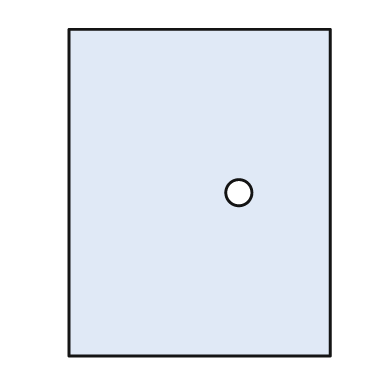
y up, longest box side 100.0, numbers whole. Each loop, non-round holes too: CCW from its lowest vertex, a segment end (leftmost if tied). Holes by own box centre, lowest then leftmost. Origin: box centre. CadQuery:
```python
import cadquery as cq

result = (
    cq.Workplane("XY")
    .moveTo(-40.0, -50.0)
    .lineTo(40.0, -50.0)
    .lineTo(40.0, 50.0)
    .lineTo(-40.0, 50.0)
    .close()
    .moveTo(12.0, 0.0)
    .circle(4.0)
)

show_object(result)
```